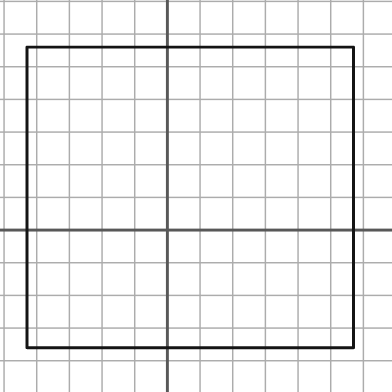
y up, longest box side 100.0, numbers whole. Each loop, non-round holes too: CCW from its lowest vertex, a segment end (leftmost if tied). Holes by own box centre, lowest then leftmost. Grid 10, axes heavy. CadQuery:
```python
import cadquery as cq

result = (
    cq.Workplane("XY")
    .moveTo(-43.0, -36.0)
    .lineTo(57.0, -36.0)
    .lineTo(57.0, 56.0)
    .lineTo(-43.0, 56.0)
    .close()
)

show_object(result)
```